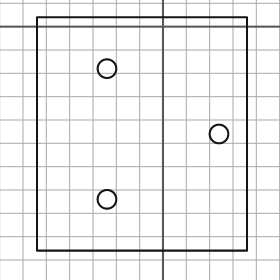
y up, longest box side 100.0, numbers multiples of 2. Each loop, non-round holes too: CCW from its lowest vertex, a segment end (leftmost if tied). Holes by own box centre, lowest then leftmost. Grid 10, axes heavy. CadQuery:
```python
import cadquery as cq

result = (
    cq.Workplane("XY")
    .moveTo(-54.0, -96.0)
    .lineTo(36.0, -96.0)
    .lineTo(36.0, 4.0)
    .lineTo(-54.0, 4.0)
    .close()
    .moveTo(-24.0, -74.0)
    .circle(4.0)
    .moveTo(24.0, -46.0)
    .circle(4.0)
    .moveTo(-24.0, -18.0)
    .circle(4.0)
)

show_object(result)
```